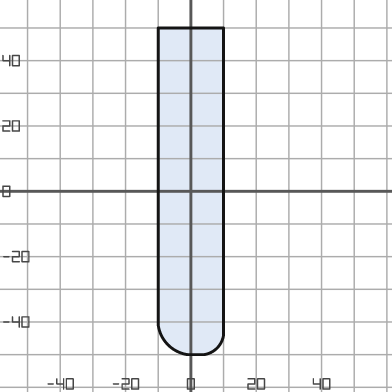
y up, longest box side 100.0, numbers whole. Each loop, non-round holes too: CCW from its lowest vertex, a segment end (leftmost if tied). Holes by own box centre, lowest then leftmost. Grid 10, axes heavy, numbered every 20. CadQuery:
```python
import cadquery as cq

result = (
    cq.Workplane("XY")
    .moveTo(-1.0, -50.0)
    .lineTo(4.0, -50.0)
    .threePointArc((8.0, -48.0), (10.0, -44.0))
    .lineTo(10.0, 50.0)
    .lineTo(-10.0, 50.0)
    .lineTo(-10.0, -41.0)
    .threePointArc((-7.0, -47.0), (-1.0, -50.0))
    .close()
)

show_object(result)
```